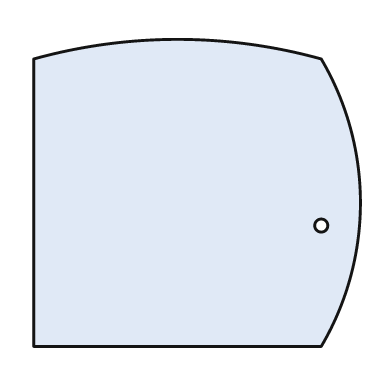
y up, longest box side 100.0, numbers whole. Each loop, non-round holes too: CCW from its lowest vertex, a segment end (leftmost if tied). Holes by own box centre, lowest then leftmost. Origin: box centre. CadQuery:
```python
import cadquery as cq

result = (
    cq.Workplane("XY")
    .moveTo(-50.0, -47.0)
    .lineTo(38.0, -47.0)
    .threePointArc((50.0, -3.0), (38.0, 41.0))
    .threePointArc((-6.0, 47.0), (-50.0, 41.0))
    .close()
    .moveTo(38.0, -10.0)
    .circle(2.0)
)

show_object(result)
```